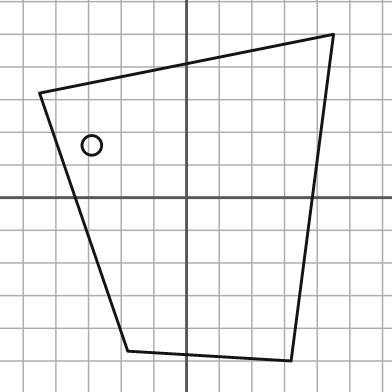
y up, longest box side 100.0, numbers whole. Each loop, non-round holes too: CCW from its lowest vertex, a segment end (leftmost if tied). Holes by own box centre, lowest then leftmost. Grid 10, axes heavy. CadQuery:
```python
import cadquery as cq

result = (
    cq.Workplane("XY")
    .moveTo(32.0, -50.0)
    .lineTo(45.0, 50.0)
    .lineTo(-45.0, 32.0)
    .lineTo(-18.0, -47.0)
    .close()
    .moveTo(-29.0, 16.0)
    .circle(3.0)
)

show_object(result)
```